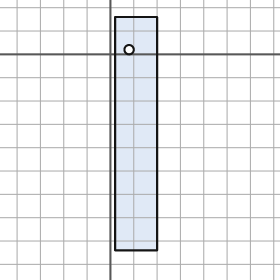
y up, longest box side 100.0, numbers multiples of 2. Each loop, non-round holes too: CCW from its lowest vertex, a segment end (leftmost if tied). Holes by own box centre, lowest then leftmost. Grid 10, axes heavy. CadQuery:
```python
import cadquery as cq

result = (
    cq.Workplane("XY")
    .moveTo(2.0, -84.0)
    .lineTo(20.0, -84.0)
    .lineTo(20.0, 16.0)
    .lineTo(2.0, 16.0)
    .close()
    .moveTo(8.0, 2.0)
    .circle(2.0)
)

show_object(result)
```